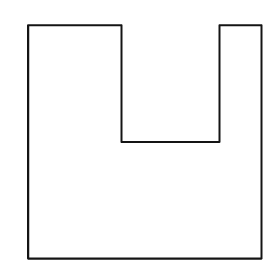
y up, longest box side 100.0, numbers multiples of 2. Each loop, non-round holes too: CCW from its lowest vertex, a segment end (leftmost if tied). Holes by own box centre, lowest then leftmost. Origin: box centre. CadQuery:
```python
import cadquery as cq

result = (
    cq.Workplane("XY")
    .moveTo(-50.0, -50.0)
    .lineTo(50.0, -50.0)
    .lineTo(50.0, 50.0)
    .lineTo(32.0, 50.0)
    .lineTo(32.0, 0.0)
    .lineTo(-10.0, 0.0)
    .lineTo(-10.0, 50.0)
    .lineTo(-50.0, 50.0)
    .close()
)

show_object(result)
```